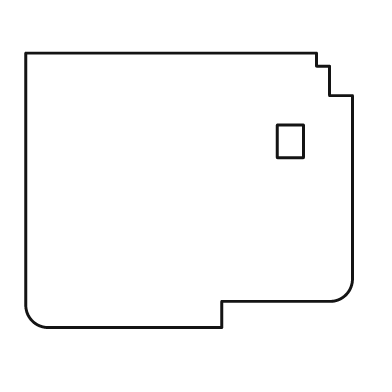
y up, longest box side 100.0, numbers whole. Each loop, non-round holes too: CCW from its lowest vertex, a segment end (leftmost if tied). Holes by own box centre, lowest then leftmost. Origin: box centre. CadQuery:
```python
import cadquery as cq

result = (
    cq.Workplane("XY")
    .moveTo(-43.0, -42.0)
    .lineTo(10.0, -42.0)
    .lineTo(10.0, -34.0)
    .lineTo(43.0, -34.0)
    .threePointArc((48.0, -32.0), (50.0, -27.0))
    .lineTo(50.0, 29.0)
    .lineTo(43.0, 29.0)
    .lineTo(43.0, 38.0)
    .lineTo(39.0, 38.0)
    .lineTo(39.0, 42.0)
    .lineTo(-50.0, 42.0)
    .lineTo(-50.0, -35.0)
    .threePointArc((-48.0, -40.0), (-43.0, -42.0))
    .close()
    .moveTo(27.0, 10.0)
    .lineTo(35.0, 10.0)
    .lineTo(35.0, 20.0)
    .lineTo(27.0, 20.0)
    .close()
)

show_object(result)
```